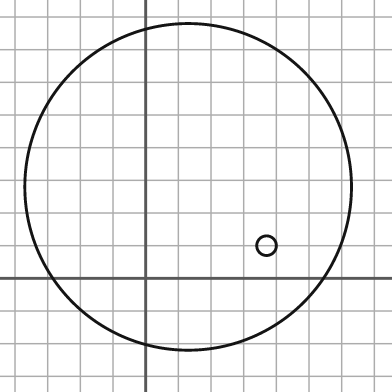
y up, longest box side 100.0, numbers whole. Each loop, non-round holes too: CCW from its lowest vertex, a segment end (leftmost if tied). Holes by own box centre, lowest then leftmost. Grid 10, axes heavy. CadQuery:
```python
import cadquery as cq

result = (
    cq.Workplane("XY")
    .moveTo(13.0, 28.0)
    .circle(50.0)
    .moveTo(37.0, 10.0)
    .circle(3.0)
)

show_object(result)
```